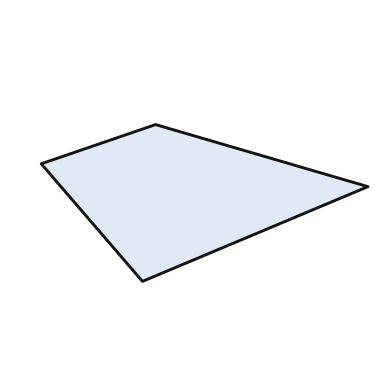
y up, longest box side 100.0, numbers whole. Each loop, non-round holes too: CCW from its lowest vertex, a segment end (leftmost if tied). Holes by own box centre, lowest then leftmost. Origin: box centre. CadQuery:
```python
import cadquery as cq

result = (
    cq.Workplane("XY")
    .moveTo(-19.0, -24.0)
    .lineTo(50.0, 5.0)
    .lineTo(-15.0, 24.0)
    .lineTo(-50.0, 12.0)
    .close()
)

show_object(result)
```